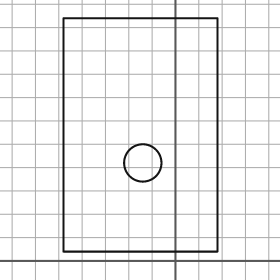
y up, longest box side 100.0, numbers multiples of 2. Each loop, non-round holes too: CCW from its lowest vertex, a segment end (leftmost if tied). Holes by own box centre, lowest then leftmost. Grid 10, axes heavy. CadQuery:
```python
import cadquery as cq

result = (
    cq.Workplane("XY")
    .moveTo(-48.0, 4.0)
    .lineTo(18.0, 4.0)
    .lineTo(18.0, 104.0)
    .lineTo(-48.0, 104.0)
    .close()
    .moveTo(-14.0, 42.0)
    .circle(8.0)
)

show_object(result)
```